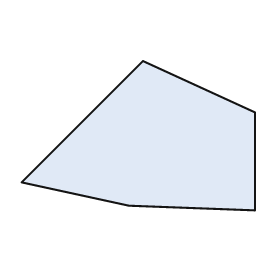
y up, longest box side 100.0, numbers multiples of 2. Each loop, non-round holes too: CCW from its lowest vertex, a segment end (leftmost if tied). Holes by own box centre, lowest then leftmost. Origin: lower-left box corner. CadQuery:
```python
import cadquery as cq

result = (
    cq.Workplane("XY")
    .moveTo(100.0, 0.0)
    .lineTo(100.0, 42.0)
    .lineTo(52.0, 64.0)
    .lineTo(0.0, 12.0)
    .lineTo(46.0, 2.0)
    .close()
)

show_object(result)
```